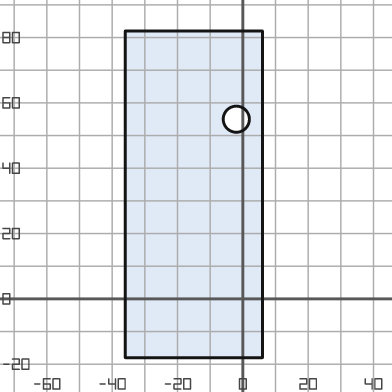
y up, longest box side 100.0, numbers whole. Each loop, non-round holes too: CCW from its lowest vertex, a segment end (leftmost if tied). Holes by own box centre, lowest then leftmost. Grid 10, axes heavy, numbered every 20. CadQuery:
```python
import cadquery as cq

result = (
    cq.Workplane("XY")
    .moveTo(-36.0, -18.0)
    .lineTo(6.0, -18.0)
    .lineTo(6.0, 82.0)
    .lineTo(-36.0, 82.0)
    .close()
    .moveTo(-2.0, 55.0)
    .circle(4.0)
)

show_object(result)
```